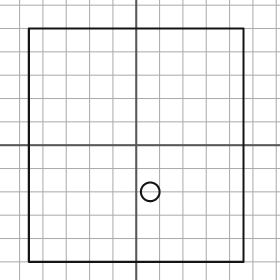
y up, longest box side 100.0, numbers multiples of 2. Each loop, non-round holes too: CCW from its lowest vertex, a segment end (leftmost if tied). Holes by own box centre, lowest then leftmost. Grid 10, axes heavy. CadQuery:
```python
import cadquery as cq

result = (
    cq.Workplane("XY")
    .moveTo(-46.0, -50.0)
    .lineTo(46.0, -50.0)
    .lineTo(46.0, 50.0)
    .lineTo(-46.0, 50.0)
    .close()
    .moveTo(6.0, -20.0)
    .circle(4.0)
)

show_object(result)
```